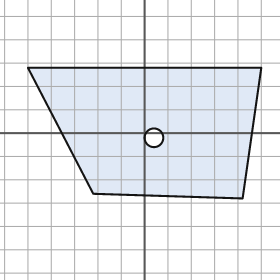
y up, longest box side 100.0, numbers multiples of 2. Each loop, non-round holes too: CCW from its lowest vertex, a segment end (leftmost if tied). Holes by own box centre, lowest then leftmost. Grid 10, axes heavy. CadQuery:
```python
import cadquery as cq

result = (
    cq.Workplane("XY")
    .moveTo(42.0, -28.0)
    .lineTo(50.0, 28.0)
    .lineTo(-50.0, 28.0)
    .lineTo(-22.0, -26.0)
    .close()
    .moveTo(4.0, -2.0)
    .circle(4.0)
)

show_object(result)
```